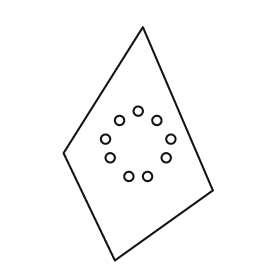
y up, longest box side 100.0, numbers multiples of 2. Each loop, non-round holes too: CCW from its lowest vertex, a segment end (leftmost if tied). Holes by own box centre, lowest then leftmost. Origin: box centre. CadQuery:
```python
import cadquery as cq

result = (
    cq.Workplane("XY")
    .moveTo(-10.0, -50.0)
    .lineTo(32.0, -20.0)
    .lineTo(2.0, 50.0)
    .lineTo(-32.0, -4.0)
    .close()
    .moveTo(-4.0, -14.0)
    .circle(2.0)
    .moveTo(4.0, -14.0)
    .circle(2.0)
    .moveTo(-12.0, -6.0)
    .circle(2.0)
    .moveTo(12.0, -6.0)
    .circle(2.0)
    .moveTo(-14.0, 2.0)
    .circle(2.0)
    .moveTo(14.0, 2.0)
    .circle(2.0)
    .moveTo(-8.0, 10.0)
    .circle(2.0)
    .moveTo(8.0, 10.0)
    .circle(2.0)
    .moveTo(0.0, 14.0)
    .circle(2.0)
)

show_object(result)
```